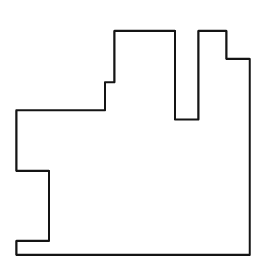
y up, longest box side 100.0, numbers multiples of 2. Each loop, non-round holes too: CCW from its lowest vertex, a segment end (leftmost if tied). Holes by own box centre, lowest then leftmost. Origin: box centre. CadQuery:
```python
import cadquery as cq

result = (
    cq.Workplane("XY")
    .moveTo(-50.0, -48.0)
    .lineTo(50.0, -48.0)
    .lineTo(50.0, 36.0)
    .lineTo(40.0, 36.0)
    .lineTo(40.0, 48.0)
    .lineTo(28.0, 48.0)
    .lineTo(28.0, 10.0)
    .lineTo(18.0, 10.0)
    .lineTo(18.0, 48.0)
    .lineTo(-8.0, 48.0)
    .lineTo(-8.0, 26.0)
    .lineTo(-12.0, 26.0)
    .lineTo(-12.0, 14.0)
    .lineTo(-50.0, 14.0)
    .lineTo(-50.0, -12.0)
    .lineTo(-36.0, -12.0)
    .lineTo(-36.0, -42.0)
    .lineTo(-50.0, -42.0)
    .close()
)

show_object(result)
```